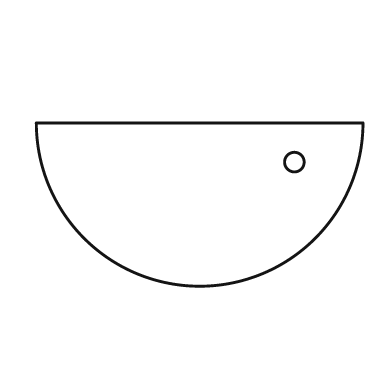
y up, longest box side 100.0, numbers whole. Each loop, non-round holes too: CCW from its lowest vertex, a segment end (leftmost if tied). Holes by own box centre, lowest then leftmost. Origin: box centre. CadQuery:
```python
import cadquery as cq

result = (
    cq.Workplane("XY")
    .moveTo(-50.0, 25.0)
    .threePointArc((0.0, -25.0), (50.0, 25.0))
    .close()
    .moveTo(29.0, 13.0)
    .circle(3.0)
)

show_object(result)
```